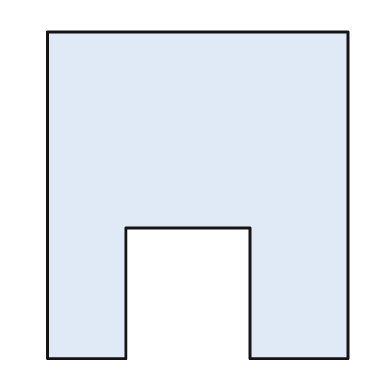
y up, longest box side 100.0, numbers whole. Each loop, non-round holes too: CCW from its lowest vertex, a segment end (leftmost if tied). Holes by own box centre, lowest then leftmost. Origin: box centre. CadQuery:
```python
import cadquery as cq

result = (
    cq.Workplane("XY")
    .moveTo(-46.0, -50.0)
    .lineTo(-22.0, -50.0)
    .lineTo(-22.0, -10.0)
    .lineTo(16.0, -10.0)
    .lineTo(16.0, -50.0)
    .lineTo(46.0, -50.0)
    .lineTo(46.0, 50.0)
    .lineTo(-46.0, 50.0)
    .close()
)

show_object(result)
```